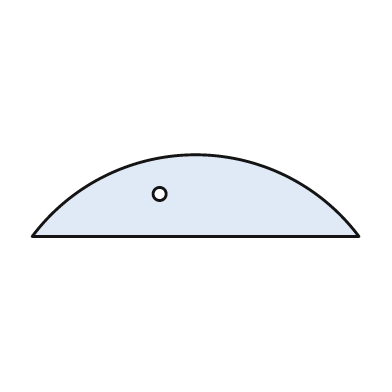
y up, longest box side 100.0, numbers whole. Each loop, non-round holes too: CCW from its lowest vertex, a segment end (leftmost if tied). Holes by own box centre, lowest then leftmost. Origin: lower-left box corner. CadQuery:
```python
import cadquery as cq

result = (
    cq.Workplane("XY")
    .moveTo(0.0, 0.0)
    .lineTo(100.0, 0.0)
    .threePointArc((50.0, 25.0), (0.0, 0.0))
    .close()
    .moveTo(39.0, 13.0)
    .circle(2.0)
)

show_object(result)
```